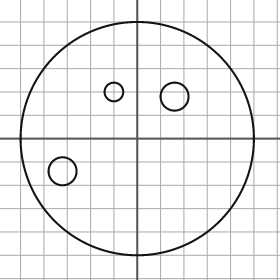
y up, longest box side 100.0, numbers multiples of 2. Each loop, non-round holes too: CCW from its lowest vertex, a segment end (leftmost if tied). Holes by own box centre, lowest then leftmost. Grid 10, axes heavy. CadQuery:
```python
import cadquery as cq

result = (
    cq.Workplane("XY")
    .moveTo(0.0, 0.0)
    .circle(50.0)
    .moveTo(-32.0, -14.0)
    .circle(6.0)
    .moveTo(16.0, 18.0)
    .circle(6.0)
    .moveTo(-10.0, 20.0)
    .circle(4.0)
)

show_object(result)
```